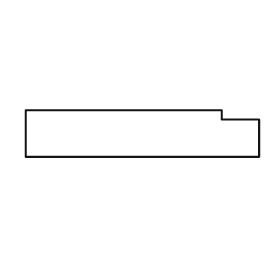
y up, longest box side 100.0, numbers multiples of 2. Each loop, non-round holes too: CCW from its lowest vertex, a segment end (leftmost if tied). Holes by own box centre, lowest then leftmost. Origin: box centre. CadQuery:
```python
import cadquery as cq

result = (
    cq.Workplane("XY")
    .moveTo(-50.0, -10.0)
    .lineTo(50.0, -10.0)
    .lineTo(50.0, 6.0)
    .lineTo(34.0, 6.0)
    .lineTo(34.0, 10.0)
    .lineTo(-50.0, 10.0)
    .close()
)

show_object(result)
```